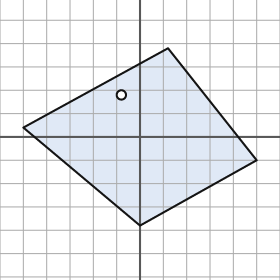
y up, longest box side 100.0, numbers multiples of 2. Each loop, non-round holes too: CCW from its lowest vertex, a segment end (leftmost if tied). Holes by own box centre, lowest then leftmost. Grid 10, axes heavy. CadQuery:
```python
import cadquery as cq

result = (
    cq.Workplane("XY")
    .moveTo(0.0, -38.0)
    .lineTo(50.0, -10.0)
    .lineTo(12.0, 38.0)
    .lineTo(-50.0, 4.0)
    .close()
    .moveTo(-8.0, 18.0)
    .circle(2.0)
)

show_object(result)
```